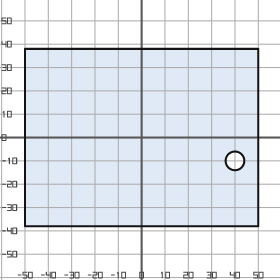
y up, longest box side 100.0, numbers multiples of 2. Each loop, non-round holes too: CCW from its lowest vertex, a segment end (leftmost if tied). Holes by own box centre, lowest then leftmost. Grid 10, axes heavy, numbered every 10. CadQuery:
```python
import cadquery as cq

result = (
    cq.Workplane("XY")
    .moveTo(-50.0, -38.0)
    .lineTo(50.0, -38.0)
    .lineTo(50.0, 38.0)
    .lineTo(-50.0, 38.0)
    .close()
    .moveTo(40.0, -10.0)
    .circle(4.0)
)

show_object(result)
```